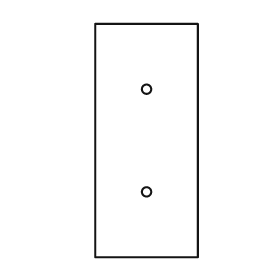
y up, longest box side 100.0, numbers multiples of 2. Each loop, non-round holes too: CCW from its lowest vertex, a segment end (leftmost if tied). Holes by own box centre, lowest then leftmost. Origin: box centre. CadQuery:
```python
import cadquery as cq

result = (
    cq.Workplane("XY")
    .moveTo(-22.0, -50.0)
    .lineTo(22.0, -50.0)
    .lineTo(22.0, 50.0)
    .lineTo(-22.0, 50.0)
    .close()
    .moveTo(0.0, -22.0)
    .circle(2.0)
    .moveTo(0.0, 22.0)
    .circle(2.0)
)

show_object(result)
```